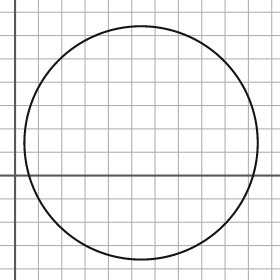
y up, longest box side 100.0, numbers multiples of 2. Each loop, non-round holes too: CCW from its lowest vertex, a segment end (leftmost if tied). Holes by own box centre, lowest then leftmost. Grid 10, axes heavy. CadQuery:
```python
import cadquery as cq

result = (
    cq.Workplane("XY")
    .moveTo(54.0, 14.0)
    .circle(50.0)
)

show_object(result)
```